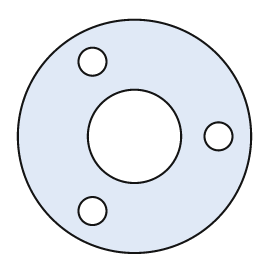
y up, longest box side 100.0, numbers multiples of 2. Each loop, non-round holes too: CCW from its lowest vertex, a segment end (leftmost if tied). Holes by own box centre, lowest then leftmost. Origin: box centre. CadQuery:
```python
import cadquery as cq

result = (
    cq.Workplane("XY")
    .moveTo(0.0, 0.0)
    .circle(50.0)
    .moveTo(-18.0, -32.0)
    .circle(6.0)
    .moveTo(0.0, 0.0)
    .circle(20.0)
    .moveTo(36.0, 0.0)
    .circle(6.0)
    .moveTo(-18.0, 32.0)
    .circle(6.0)
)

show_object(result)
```